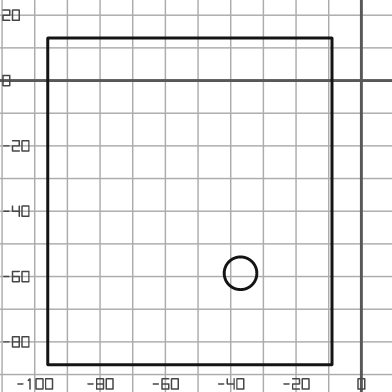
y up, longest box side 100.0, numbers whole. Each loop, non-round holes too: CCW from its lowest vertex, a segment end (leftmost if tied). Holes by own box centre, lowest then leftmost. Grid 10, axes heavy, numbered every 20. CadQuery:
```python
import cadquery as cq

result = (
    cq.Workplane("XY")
    .moveTo(-96.0, -87.0)
    .lineTo(-9.0, -87.0)
    .lineTo(-9.0, 13.0)
    .lineTo(-96.0, 13.0)
    .close()
    .moveTo(-37.0, -59.0)
    .circle(5.0)
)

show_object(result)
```